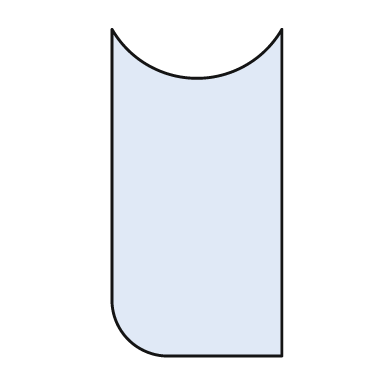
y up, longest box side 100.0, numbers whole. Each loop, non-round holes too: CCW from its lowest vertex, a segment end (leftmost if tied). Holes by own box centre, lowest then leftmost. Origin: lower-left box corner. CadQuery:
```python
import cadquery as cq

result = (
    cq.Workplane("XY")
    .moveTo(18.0, 0.0)
    .lineTo(52.0, 0.0)
    .lineTo(52.0, 100.0)
    .threePointArc((26.0, 85.0), (0.0, 100.0))
    .lineTo(0.0, 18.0)
    .threePointArc((5.0, 5.0), (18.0, 0.0))
    .close()
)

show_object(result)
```